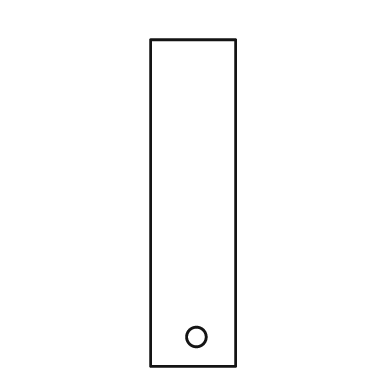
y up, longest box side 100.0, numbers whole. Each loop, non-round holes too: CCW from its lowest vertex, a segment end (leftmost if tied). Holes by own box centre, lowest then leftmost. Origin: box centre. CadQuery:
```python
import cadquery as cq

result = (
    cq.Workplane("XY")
    .moveTo(-13.0, -50.0)
    .lineTo(13.0, -50.0)
    .lineTo(13.0, 50.0)
    .lineTo(-13.0, 50.0)
    .close()
    .moveTo(1.0, -41.0)
    .circle(3.0)
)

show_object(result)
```